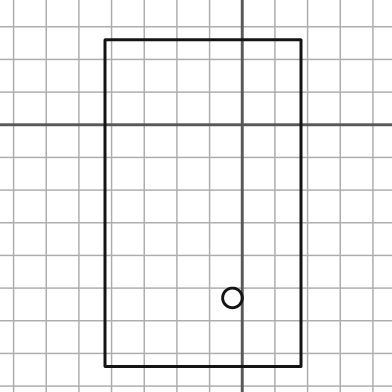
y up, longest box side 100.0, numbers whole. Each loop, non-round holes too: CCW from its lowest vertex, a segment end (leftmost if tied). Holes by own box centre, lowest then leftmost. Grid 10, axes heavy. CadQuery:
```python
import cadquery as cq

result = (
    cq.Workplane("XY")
    .moveTo(-42.0, -74.0)
    .lineTo(18.0, -74.0)
    .lineTo(18.0, 26.0)
    .lineTo(-42.0, 26.0)
    .close()
    .moveTo(-3.0, -53.0)
    .circle(3.0)
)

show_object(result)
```